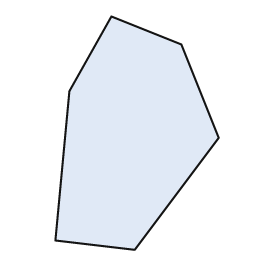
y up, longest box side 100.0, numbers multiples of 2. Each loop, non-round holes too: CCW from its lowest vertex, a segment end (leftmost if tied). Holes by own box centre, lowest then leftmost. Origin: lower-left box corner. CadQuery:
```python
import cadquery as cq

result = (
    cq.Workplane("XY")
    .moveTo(34.0, 0.0)
    .lineTo(70.0, 48.0)
    .lineTo(54.0, 88.0)
    .lineTo(24.0, 100.0)
    .lineTo(6.0, 68.0)
    .lineTo(0.0, 4.0)
    .close()
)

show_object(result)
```